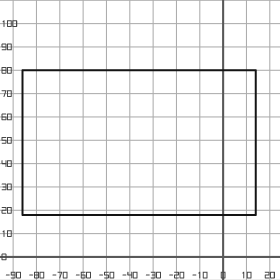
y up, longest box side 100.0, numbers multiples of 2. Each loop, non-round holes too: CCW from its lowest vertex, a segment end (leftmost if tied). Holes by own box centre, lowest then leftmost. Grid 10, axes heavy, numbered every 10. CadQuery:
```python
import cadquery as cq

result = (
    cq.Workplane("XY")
    .moveTo(-86.0, 18.0)
    .lineTo(14.0, 18.0)
    .lineTo(14.0, 80.0)
    .lineTo(-86.0, 80.0)
    .close()
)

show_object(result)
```